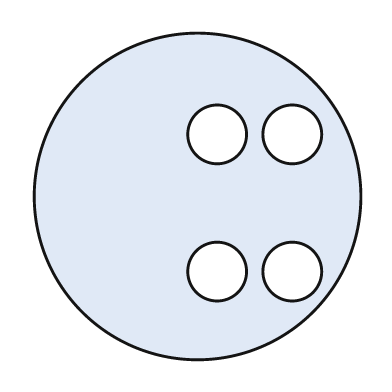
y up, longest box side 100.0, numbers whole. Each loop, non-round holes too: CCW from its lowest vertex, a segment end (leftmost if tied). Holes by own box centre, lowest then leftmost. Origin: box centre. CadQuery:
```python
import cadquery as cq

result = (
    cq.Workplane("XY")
    .moveTo(0.0, 0.0)
    .circle(50.0)
    .moveTo(6.0, -23.0)
    .circle(9.0)
    .moveTo(29.0, -23.0)
    .circle(9.0)
    .moveTo(6.0, 19.0)
    .circle(9.0)
    .moveTo(29.0, 19.0)
    .circle(9.0)
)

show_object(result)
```